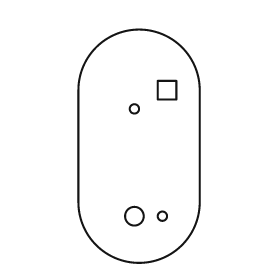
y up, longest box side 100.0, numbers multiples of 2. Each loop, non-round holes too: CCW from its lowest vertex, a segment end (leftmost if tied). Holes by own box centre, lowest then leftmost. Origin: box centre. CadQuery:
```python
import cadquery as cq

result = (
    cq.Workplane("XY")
    .moveTo(-26.0, -24.0)
    .threePointArc((0.0, -50.0), (26.0, -24.0))
    .lineTo(26.0, 24.0)
    .threePointArc((0.0, 50.0), (-26.0, 24.0))
    .close()
    .moveTo(-2.0, -30.0)
    .circle(4.0)
    .moveTo(10.0, -30.0)
    .circle(2.0)
    .moveTo(-2.0, 16.0)
    .circle(2.0)
    .moveTo(8.0, 20.0)
    .lineTo(16.0, 20.0)
    .lineTo(16.0, 28.0)
    .lineTo(8.0, 28.0)
    .close()
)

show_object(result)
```